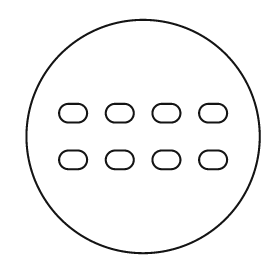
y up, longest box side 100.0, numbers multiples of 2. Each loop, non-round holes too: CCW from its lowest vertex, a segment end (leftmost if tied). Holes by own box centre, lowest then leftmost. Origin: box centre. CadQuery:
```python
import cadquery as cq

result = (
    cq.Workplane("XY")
    .moveTo(0.0, 0.0)
    .circle(50.0)
    .moveTo(-32.0, -14.0)
    .lineTo(-28.0, -14.0)
    .threePointArc((-24.0, -10.0), (-28.0, -6.0))
    .lineTo(-32.0, -6.0)
    .threePointArc((-36.0, -10.0), (-32.0, -14.0))
    .close()
    .moveTo(-12.0, -14.0)
    .lineTo(-8.0, -14.0)
    .threePointArc((-4.0, -10.0), (-8.0, -6.0))
    .lineTo(-12.0, -6.0)
    .threePointArc((-16.0, -10.0), (-12.0, -14.0))
    .close()
    .moveTo(8.0, -14.0)
    .lineTo(12.0, -14.0)
    .threePointArc((16.0, -10.0), (12.0, -6.0))
    .lineTo(8.0, -6.0)
    .threePointArc((4.0, -10.0), (8.0, -14.0))
    .close()
    .moveTo(28.0, -14.0)
    .lineTo(32.0, -14.0)
    .threePointArc((36.0, -10.0), (32.0, -6.0))
    .lineTo(28.0, -6.0)
    .threePointArc((24.0, -10.0), (28.0, -14.0))
    .close()
    .moveTo(-32.0, 6.0)
    .lineTo(-28.0, 6.0)
    .threePointArc((-24.0, 10.0), (-28.0, 14.0))
    .lineTo(-32.0, 14.0)
    .threePointArc((-36.0, 10.0), (-32.0, 6.0))
    .close()
    .moveTo(-12.0, 6.0)
    .lineTo(-8.0, 6.0)
    .threePointArc((-4.0, 10.0), (-8.0, 14.0))
    .lineTo(-12.0, 14.0)
    .threePointArc((-16.0, 10.0), (-12.0, 6.0))
    .close()
    .moveTo(8.0, 6.0)
    .lineTo(12.0, 6.0)
    .threePointArc((16.0, 10.0), (12.0, 14.0))
    .lineTo(8.0, 14.0)
    .threePointArc((4.0, 10.0), (8.0, 6.0))
    .close()
    .moveTo(28.0, 6.0)
    .lineTo(32.0, 6.0)
    .threePointArc((36.0, 10.0), (32.0, 14.0))
    .lineTo(28.0, 14.0)
    .threePointArc((24.0, 10.0), (28.0, 6.0))
    .close()
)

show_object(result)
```